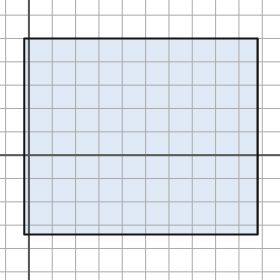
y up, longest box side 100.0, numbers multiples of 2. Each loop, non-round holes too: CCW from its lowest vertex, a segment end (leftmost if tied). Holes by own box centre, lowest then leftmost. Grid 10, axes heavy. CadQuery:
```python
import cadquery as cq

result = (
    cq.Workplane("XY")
    .moveTo(-2.0, -34.0)
    .lineTo(98.0, -34.0)
    .lineTo(98.0, 50.0)
    .lineTo(-2.0, 50.0)
    .close()
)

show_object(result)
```